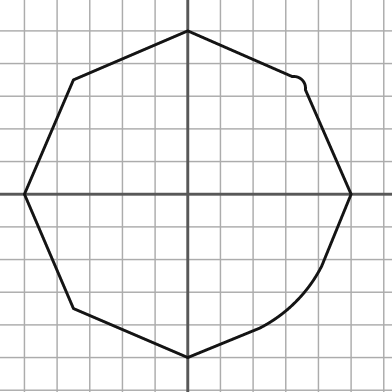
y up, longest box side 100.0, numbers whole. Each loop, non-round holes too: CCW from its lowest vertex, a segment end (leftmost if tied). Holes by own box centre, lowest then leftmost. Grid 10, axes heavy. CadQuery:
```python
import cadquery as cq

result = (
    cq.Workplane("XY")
    .moveTo(0.0, -50.0)
    .lineTo(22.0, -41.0)
    .threePointArc((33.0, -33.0), (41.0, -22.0))
    .lineTo(50.0, 0.0)
    .lineTo(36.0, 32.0)
    .threePointArc((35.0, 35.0), (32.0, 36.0))
    .lineTo(0.0, 50.0)
    .lineTo(-35.0, 35.0)
    .lineTo(-50.0, 0.0)
    .lineTo(-35.0, -35.0)
    .close()
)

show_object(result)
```